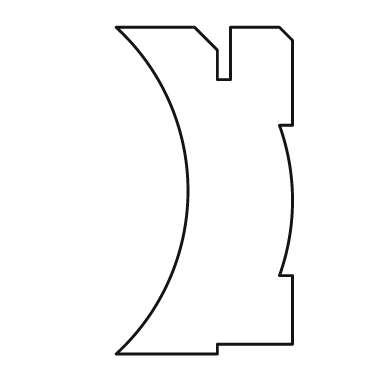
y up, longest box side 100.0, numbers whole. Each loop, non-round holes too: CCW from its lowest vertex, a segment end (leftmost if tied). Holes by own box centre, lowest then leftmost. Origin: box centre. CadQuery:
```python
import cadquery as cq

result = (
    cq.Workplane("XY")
    .moveTo(-27.0, -50.0)
    .lineTo(4.0, -50.0)
    .lineTo(4.0, -47.0)
    .lineTo(27.0, -47.0)
    .lineTo(27.0, -26.0)
    .lineTo(23.0, -26.0)
    .threePointArc((27.0, -3.0), (23.0, 20.0))
    .lineTo(27.0, 20.0)
    .lineTo(27.0, 46.0)
    .lineTo(23.0, 50.0)
    .lineTo(8.0, 50.0)
    .lineTo(8.0, 34.0)
    .lineTo(4.0, 34.0)
    .lineTo(4.0, 43.0)
    .lineTo(-3.0, 50.0)
    .lineTo(-27.0, 50.0)
    .threePointArc((-5.0, 0.0), (-27.0, -50.0))
    .close()
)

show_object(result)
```